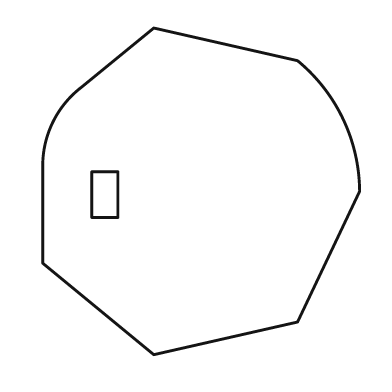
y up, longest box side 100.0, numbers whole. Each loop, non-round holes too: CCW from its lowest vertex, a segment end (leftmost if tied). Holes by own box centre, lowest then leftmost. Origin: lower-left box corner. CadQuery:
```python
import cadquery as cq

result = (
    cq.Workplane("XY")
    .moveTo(34.0, 0.0)
    .lineTo(78.0, 10.0)
    .lineTo(97.0, 50.0)
    .threePointArc((92.0, 72.0), (78.0, 90.0))
    .lineTo(34.0, 100.0)
    .lineTo(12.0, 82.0)
    .threePointArc((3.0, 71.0), (0.0, 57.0))
    .lineTo(0.0, 28.0)
    .close()
    .moveTo(15.0, 42.0)
    .lineTo(23.0, 42.0)
    .lineTo(23.0, 56.0)
    .lineTo(15.0, 56.0)
    .close()
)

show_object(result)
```